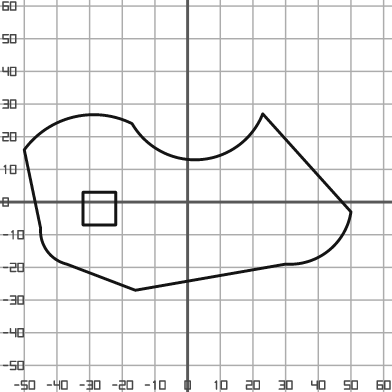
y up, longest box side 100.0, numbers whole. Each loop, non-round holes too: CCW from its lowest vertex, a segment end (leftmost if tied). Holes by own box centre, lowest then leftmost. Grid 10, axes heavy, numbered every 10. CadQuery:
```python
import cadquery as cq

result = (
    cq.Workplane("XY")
    .moveTo(-16.0, -27.0)
    .lineTo(30.0, -19.0)
    .threePointArc((43.0, -15.0), (50.0, -3.0))
    .lineTo(23.0, 27.0)
    .threePointArc((4.0, 13.0), (-17.0, 24.0))
    .threePointArc((-35.0, 26.0), (-50.0, 16.0))
    .lineTo(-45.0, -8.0)
    .threePointArc((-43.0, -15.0), (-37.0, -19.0))
    .close()
    .moveTo(-32.0, -7.0)
    .lineTo(-22.0, -7.0)
    .lineTo(-22.0, 3.0)
    .lineTo(-32.0, 3.0)
    .close()
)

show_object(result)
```